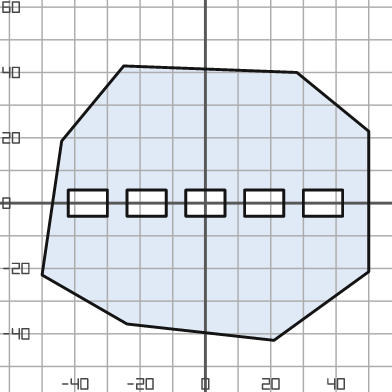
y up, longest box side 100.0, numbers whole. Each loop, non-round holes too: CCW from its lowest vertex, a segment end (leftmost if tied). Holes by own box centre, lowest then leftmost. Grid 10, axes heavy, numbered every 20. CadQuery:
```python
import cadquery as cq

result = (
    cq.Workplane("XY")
    .moveTo(21.0, -42.0)
    .lineTo(50.0, -21.0)
    .lineTo(50.0, 22.0)
    .lineTo(28.0, 40.0)
    .lineTo(-25.0, 42.0)
    .lineTo(-44.0, 19.0)
    .lineTo(-50.0, -22.0)
    .lineTo(-24.0, -37.0)
    .close()
    .moveTo(-42.0, -4.0)
    .lineTo(-30.0, -4.0)
    .lineTo(-30.0, 4.0)
    .lineTo(-42.0, 4.0)
    .close()
    .moveTo(-24.0, -4.0)
    .lineTo(-12.0, -4.0)
    .lineTo(-12.0, 4.0)
    .lineTo(-24.0, 4.0)
    .close()
    .moveTo(-6.0, -4.0)
    .lineTo(6.0, -4.0)
    .lineTo(6.0, 4.0)
    .lineTo(-6.0, 4.0)
    .close()
    .moveTo(12.0, -4.0)
    .lineTo(24.0, -4.0)
    .lineTo(24.0, 4.0)
    .lineTo(12.0, 4.0)
    .close()
    .moveTo(30.0, -4.0)
    .lineTo(42.0, -4.0)
    .lineTo(42.0, 4.0)
    .lineTo(30.0, 4.0)
    .close()
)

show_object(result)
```